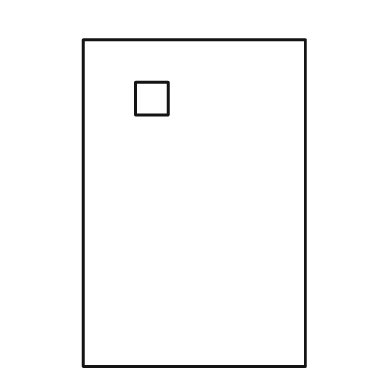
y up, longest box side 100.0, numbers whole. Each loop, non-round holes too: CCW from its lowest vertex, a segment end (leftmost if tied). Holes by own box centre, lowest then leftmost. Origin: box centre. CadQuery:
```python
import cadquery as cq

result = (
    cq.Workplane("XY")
    .moveTo(-34.0, -50.0)
    .lineTo(34.0, -50.0)
    .lineTo(34.0, 50.0)
    .lineTo(-34.0, 50.0)
    .close()
    .moveTo(-18.0, 27.0)
    .lineTo(-8.0, 27.0)
    .lineTo(-8.0, 37.0)
    .lineTo(-18.0, 37.0)
    .close()
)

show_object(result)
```